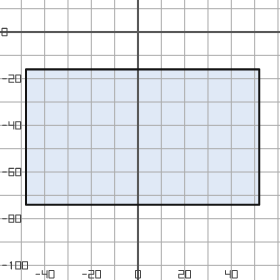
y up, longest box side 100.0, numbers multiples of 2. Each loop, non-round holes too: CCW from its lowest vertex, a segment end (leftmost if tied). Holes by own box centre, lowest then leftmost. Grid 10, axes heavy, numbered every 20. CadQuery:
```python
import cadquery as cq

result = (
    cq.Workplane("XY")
    .moveTo(-48.0, -74.0)
    .lineTo(52.0, -74.0)
    .lineTo(52.0, -16.0)
    .lineTo(-48.0, -16.0)
    .close()
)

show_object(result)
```